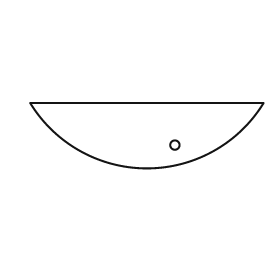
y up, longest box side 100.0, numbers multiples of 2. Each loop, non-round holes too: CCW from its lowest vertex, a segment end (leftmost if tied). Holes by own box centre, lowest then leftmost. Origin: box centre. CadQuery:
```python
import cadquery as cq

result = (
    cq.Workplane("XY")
    .moveTo(-50.0, 14.0)
    .threePointArc((0.0, -14.0), (50.0, 14.0))
    .close()
    .moveTo(12.0, -4.0)
    .circle(2.0)
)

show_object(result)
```